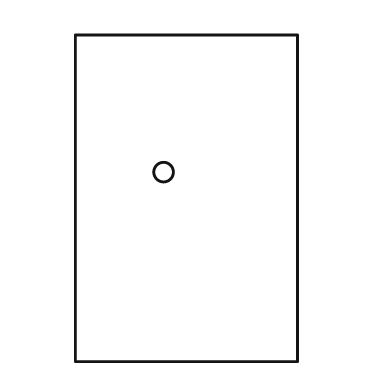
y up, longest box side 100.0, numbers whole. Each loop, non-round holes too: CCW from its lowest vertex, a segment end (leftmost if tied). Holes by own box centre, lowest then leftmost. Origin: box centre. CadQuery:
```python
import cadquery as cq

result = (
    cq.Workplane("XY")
    .moveTo(-34.0, -50.0)
    .lineTo(34.0, -50.0)
    .lineTo(34.0, 50.0)
    .lineTo(-34.0, 50.0)
    .close()
    .moveTo(-7.0, 8.0)
    .circle(3.0)
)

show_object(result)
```